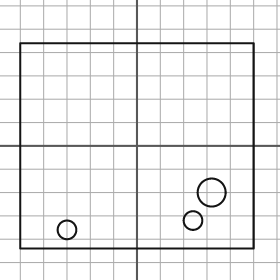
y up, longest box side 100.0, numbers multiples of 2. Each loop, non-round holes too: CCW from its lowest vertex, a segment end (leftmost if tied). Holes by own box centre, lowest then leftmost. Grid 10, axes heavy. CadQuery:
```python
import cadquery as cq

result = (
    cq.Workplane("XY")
    .moveTo(-50.0, -44.0)
    .lineTo(50.0, -44.0)
    .lineTo(50.0, 44.0)
    .lineTo(-50.0, 44.0)
    .close()
    .moveTo(-30.0, -36.0)
    .circle(4.0)
    .moveTo(24.0, -32.0)
    .circle(4.0)
    .moveTo(32.0, -20.0)
    .circle(6.0)
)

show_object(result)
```